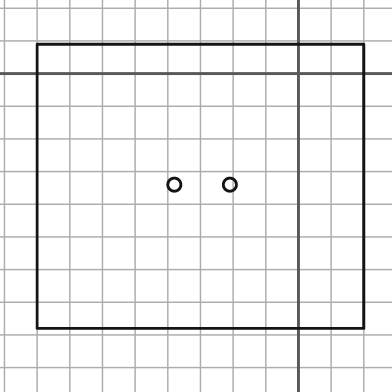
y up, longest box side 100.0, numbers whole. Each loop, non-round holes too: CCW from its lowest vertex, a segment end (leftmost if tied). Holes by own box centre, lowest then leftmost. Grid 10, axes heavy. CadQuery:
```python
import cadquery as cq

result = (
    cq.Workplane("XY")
    .moveTo(-80.0, -78.0)
    .lineTo(20.0, -78.0)
    .lineTo(20.0, 9.0)
    .lineTo(-80.0, 9.0)
    .close()
    .moveTo(-38.0, -34.0)
    .circle(2.0)
    .moveTo(-21.0, -34.0)
    .circle(2.0)
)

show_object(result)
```